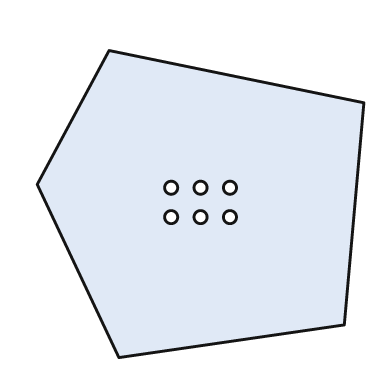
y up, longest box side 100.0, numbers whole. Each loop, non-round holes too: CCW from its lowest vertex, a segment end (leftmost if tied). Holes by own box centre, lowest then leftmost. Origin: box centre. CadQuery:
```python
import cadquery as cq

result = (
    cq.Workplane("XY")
    .moveTo(-25.0, -47.0)
    .lineTo(44.0, -37.0)
    .lineTo(50.0, 31.0)
    .lineTo(-28.0, 47.0)
    .lineTo(-50.0, 6.0)
    .close()
    .moveTo(-9.0, -4.0)
    .circle(2.0)
    .moveTo(0.0, -4.0)
    .circle(2.0)
    .moveTo(9.0, -4.0)
    .circle(2.0)
    .moveTo(-9.0, 5.0)
    .circle(2.0)
    .moveTo(0.0, 5.0)
    .circle(2.0)
    .moveTo(9.0, 5.0)
    .circle(2.0)
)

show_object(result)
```